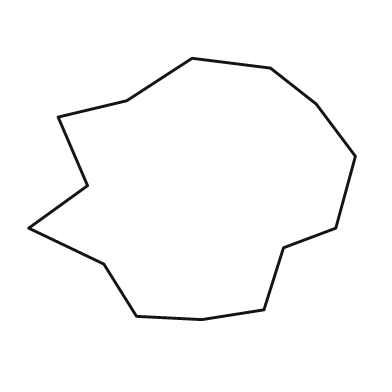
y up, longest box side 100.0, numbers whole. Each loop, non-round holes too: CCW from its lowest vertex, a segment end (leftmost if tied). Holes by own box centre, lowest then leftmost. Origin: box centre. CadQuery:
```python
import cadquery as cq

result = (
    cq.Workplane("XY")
    .moveTo(3.0, -40.0)
    .lineTo(22.0, -37.0)
    .lineTo(28.0, -18.0)
    .lineTo(44.0, -12.0)
    .lineTo(50.0, 10.0)
    .lineTo(38.0, 26.0)
    .lineTo(24.0, 37.0)
    .lineTo(0.0, 40.0)
    .lineTo(-20.0, 27.0)
    .lineTo(-41.0, 22.0)
    .lineTo(-32.0, 1.0)
    .lineTo(-50.0, -12.0)
    .lineTo(-27.0, -23.0)
    .lineTo(-17.0, -39.0)
    .close()
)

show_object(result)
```